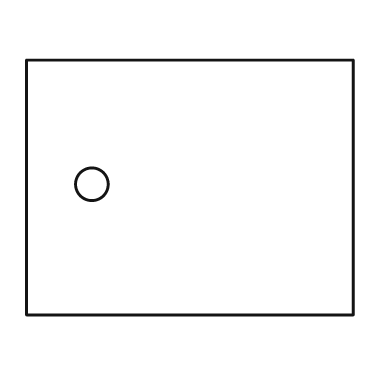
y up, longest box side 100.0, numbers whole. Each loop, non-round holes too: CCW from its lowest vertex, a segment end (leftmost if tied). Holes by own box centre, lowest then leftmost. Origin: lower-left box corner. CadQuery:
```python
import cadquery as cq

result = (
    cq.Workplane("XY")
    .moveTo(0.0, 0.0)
    .lineTo(100.0, 0.0)
    .lineTo(100.0, 78.0)
    .lineTo(0.0, 78.0)
    .close()
    .moveTo(20.0, 40.0)
    .circle(5.0)
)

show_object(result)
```